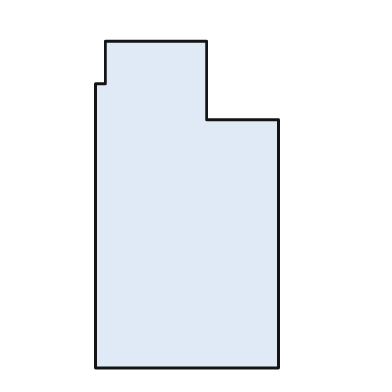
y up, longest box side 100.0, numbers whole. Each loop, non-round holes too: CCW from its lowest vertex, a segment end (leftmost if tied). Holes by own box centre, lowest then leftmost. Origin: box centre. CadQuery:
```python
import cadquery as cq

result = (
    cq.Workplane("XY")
    .moveTo(-28.0, -50.0)
    .lineTo(28.0, -50.0)
    .lineTo(28.0, 26.0)
    .lineTo(6.0, 26.0)
    .lineTo(6.0, 50.0)
    .lineTo(-25.0, 50.0)
    .lineTo(-25.0, 37.0)
    .lineTo(-28.0, 37.0)
    .close()
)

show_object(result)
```